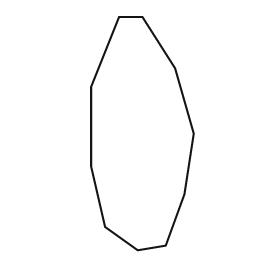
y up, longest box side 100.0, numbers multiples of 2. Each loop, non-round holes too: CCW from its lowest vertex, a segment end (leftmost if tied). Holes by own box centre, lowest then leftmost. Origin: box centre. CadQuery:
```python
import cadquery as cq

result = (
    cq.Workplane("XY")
    .moveTo(-2.0, -50.0)
    .lineTo(10.0, -48.0)
    .lineTo(18.0, -26.0)
    .lineTo(22.0, 0.0)
    .lineTo(14.0, 28.0)
    .lineTo(0.0, 50.0)
    .lineTo(-10.0, 50.0)
    .lineTo(-22.0, 20.0)
    .lineTo(-22.0, -14.0)
    .lineTo(-16.0, -40.0)
    .close()
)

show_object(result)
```